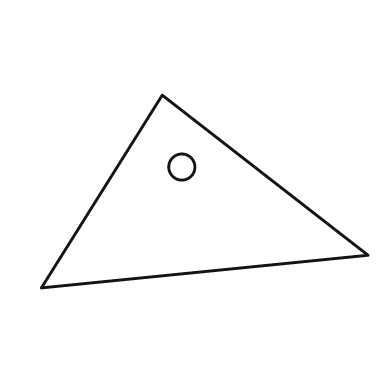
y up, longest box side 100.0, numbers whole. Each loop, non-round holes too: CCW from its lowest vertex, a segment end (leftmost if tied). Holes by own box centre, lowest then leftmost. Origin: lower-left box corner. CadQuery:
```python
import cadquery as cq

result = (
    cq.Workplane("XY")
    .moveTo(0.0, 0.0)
    .lineTo(100.0, 10.0)
    .lineTo(37.0, 59.0)
    .close()
    .moveTo(43.0, 37.0)
    .circle(4.0)
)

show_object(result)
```